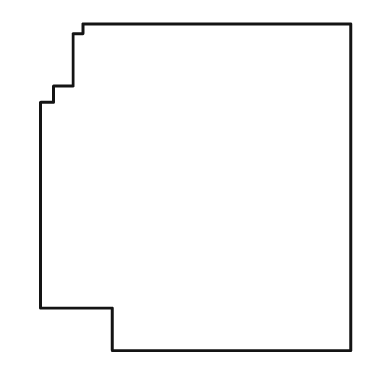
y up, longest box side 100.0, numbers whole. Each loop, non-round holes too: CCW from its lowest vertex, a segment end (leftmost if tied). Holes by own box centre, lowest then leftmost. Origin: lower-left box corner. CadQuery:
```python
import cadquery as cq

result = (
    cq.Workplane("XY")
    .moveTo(22.0, 0.0)
    .lineTo(95.0, 0.0)
    .lineTo(95.0, 100.0)
    .lineTo(13.0, 100.0)
    .lineTo(13.0, 97.0)
    .lineTo(10.0, 97.0)
    .lineTo(10.0, 81.0)
    .lineTo(4.0, 81.0)
    .lineTo(4.0, 76.0)
    .lineTo(0.0, 76.0)
    .lineTo(0.0, 13.0)
    .lineTo(22.0, 13.0)
    .close()
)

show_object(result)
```